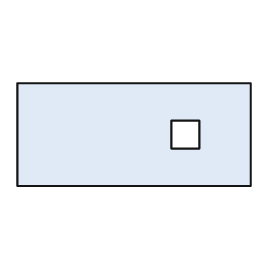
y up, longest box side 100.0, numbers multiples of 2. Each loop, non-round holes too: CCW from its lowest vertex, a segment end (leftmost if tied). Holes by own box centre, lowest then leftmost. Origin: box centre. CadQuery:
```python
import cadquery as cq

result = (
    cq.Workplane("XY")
    .moveTo(-50.0, -22.0)
    .lineTo(50.0, -22.0)
    .lineTo(50.0, 22.0)
    .lineTo(-50.0, 22.0)
    .close()
    .moveTo(16.0, -6.0)
    .lineTo(28.0, -6.0)
    .lineTo(28.0, 6.0)
    .lineTo(16.0, 6.0)
    .close()
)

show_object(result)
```